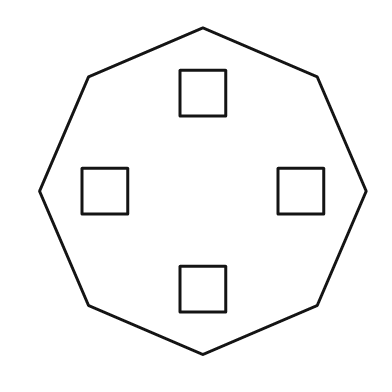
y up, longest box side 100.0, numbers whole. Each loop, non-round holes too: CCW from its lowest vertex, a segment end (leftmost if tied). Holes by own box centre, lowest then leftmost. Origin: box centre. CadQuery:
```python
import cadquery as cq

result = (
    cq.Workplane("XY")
    .moveTo(0.0, -50.0)
    .lineTo(35.0, -35.0)
    .lineTo(50.0, 0.0)
    .lineTo(35.0, 35.0)
    .lineTo(0.0, 50.0)
    .lineTo(-35.0, 35.0)
    .lineTo(-50.0, 0.0)
    .lineTo(-35.0, -35.0)
    .close()
    .moveTo(-7.0, -37.0)
    .lineTo(7.0, -37.0)
    .lineTo(7.0, -23.0)
    .lineTo(-7.0, -23.0)
    .close()
    .moveTo(-37.0, -7.0)
    .lineTo(-23.0, -7.0)
    .lineTo(-23.0, 7.0)
    .lineTo(-37.0, 7.0)
    .close()
    .moveTo(23.0, -7.0)
    .lineTo(37.0, -7.0)
    .lineTo(37.0, 7.0)
    .lineTo(23.0, 7.0)
    .close()
    .moveTo(-7.0, 23.0)
    .lineTo(7.0, 23.0)
    .lineTo(7.0, 37.0)
    .lineTo(-7.0, 37.0)
    .close()
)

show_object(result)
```